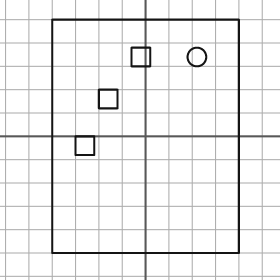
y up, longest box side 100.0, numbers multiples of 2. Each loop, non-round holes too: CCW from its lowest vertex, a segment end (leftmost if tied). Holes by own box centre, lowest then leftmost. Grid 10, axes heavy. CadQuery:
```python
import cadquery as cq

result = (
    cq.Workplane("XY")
    .moveTo(-40.0, -50.0)
    .lineTo(40.0, -50.0)
    .lineTo(40.0, 50.0)
    .lineTo(-40.0, 50.0)
    .close()
    .moveTo(-30.0, -8.0)
    .lineTo(-22.0, -8.0)
    .lineTo(-22.0, 0.0)
    .lineTo(-30.0, 0.0)
    .close()
    .moveTo(-20.0, 12.0)
    .lineTo(-12.0, 12.0)
    .lineTo(-12.0, 20.0)
    .lineTo(-20.0, 20.0)
    .close()
    .moveTo(-6.0, 30.0)
    .lineTo(2.0, 30.0)
    .lineTo(2.0, 38.0)
    .lineTo(-6.0, 38.0)
    .close()
    .moveTo(22.0, 34.0)
    .circle(4.0)
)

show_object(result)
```